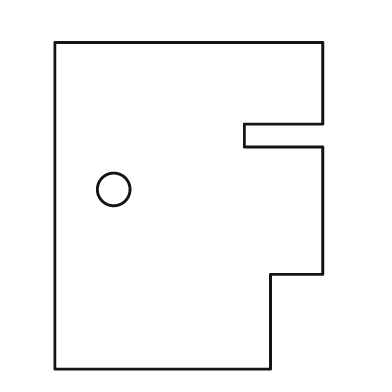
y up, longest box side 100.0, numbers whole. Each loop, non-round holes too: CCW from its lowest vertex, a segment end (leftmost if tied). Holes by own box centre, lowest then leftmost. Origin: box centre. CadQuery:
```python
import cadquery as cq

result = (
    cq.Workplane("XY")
    .moveTo(-41.0, -50.0)
    .lineTo(25.0, -50.0)
    .lineTo(25.0, -21.0)
    .lineTo(41.0, -21.0)
    .lineTo(41.0, 18.0)
    .lineTo(17.0, 18.0)
    .lineTo(17.0, 25.0)
    .lineTo(41.0, 25.0)
    .lineTo(41.0, 50.0)
    .lineTo(-41.0, 50.0)
    .close()
    .moveTo(-23.0, 5.0)
    .circle(5.0)
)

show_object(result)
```